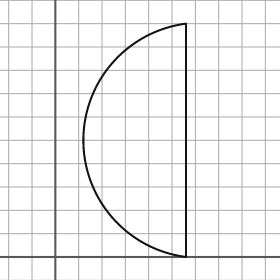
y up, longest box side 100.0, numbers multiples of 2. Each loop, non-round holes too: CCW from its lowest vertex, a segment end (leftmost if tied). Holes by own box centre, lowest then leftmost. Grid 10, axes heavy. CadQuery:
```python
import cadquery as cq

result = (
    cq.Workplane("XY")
    .moveTo(56.0, 0.0)
    .lineTo(56.0, 100.0)
    .threePointArc((12.0, 50.0), (56.0, 0.0))
    .close()
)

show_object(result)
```